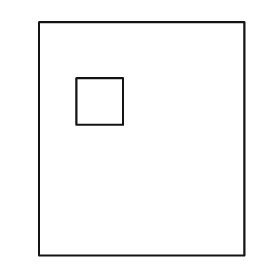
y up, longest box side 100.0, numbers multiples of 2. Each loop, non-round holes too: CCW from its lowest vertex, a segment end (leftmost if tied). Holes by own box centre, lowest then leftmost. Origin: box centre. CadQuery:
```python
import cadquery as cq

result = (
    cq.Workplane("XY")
    .moveTo(-44.0, -50.0)
    .lineTo(44.0, -50.0)
    .lineTo(44.0, 50.0)
    .lineTo(-44.0, 50.0)
    .close()
    .moveTo(-28.0, 6.0)
    .lineTo(-8.0, 6.0)
    .lineTo(-8.0, 26.0)
    .lineTo(-28.0, 26.0)
    .close()
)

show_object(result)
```